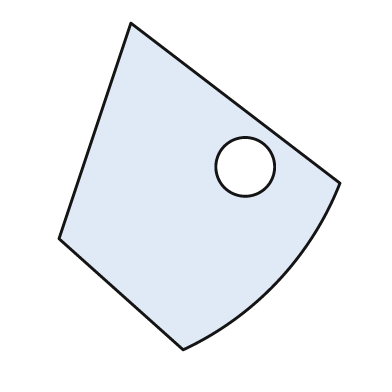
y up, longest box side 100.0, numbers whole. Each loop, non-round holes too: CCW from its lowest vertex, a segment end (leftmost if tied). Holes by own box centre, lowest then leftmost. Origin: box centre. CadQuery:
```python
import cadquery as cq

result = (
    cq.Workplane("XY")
    .moveTo(-5.0, -50.0)
    .threePointArc((24.0, -29.0), (43.0, 1.0))
    .lineTo(-21.0, 50.0)
    .lineTo(-43.0, -16.0)
    .close()
    .moveTo(14.0, 6.0)
    .circle(9.0)
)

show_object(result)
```